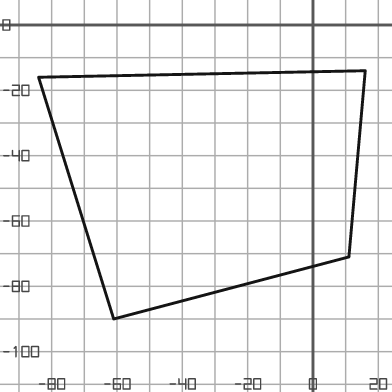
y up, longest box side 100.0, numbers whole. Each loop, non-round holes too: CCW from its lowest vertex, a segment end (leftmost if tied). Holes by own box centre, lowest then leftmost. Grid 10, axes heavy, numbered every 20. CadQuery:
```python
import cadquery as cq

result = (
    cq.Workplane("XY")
    .moveTo(-61.0, -90.0)
    .lineTo(11.0, -71.0)
    .lineTo(16.0, -14.0)
    .lineTo(-84.0, -16.0)
    .close()
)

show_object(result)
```